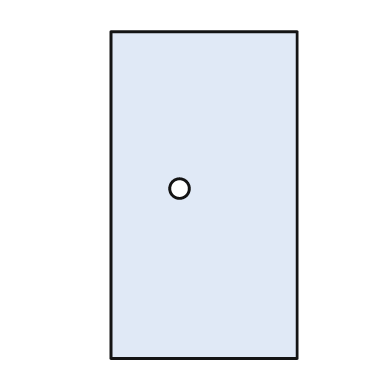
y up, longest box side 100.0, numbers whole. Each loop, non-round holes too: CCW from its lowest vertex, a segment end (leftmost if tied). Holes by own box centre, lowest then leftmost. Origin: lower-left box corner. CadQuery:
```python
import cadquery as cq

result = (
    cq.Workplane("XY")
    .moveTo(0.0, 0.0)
    .lineTo(57.0, 0.0)
    .lineTo(57.0, 100.0)
    .lineTo(0.0, 100.0)
    .close()
    .moveTo(21.0, 52.0)
    .circle(3.0)
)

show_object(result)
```